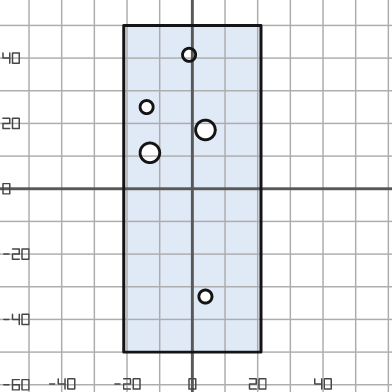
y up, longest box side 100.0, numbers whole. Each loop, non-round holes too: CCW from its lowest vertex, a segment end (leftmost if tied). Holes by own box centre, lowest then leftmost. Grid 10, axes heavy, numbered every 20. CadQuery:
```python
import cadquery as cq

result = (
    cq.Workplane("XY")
    .moveTo(-21.0, -50.0)
    .lineTo(21.0, -50.0)
    .lineTo(21.0, 50.0)
    .lineTo(-21.0, 50.0)
    .close()
    .moveTo(4.0, -33.0)
    .circle(2.0)
    .moveTo(-13.0, 11.0)
    .circle(3.0)
    .moveTo(4.0, 18.0)
    .circle(3.0)
    .moveTo(-14.0, 25.0)
    .circle(2.0)
    .moveTo(-1.0, 41.0)
    .circle(2.0)
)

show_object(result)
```